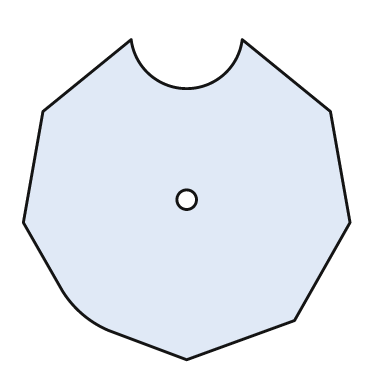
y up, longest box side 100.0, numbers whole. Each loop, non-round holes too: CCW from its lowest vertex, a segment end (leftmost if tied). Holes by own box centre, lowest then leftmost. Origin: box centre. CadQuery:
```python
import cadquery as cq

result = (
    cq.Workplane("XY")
    .moveTo(0.0, -49.0)
    .lineTo(33.0, -37.0)
    .lineTo(50.0, -7.0)
    .lineTo(44.0, 27.0)
    .lineTo(17.0, 49.0)
    .threePointArc((0.0, 34.0), (-17.0, 49.0))
    .lineTo(-44.0, 27.0)
    .lineTo(-50.0, -7.0)
    .lineTo(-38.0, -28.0)
    .threePointArc((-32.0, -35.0), (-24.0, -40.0))
    .close()
    .moveTo(0.0, 0.0)
    .circle(3.0)
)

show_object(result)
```